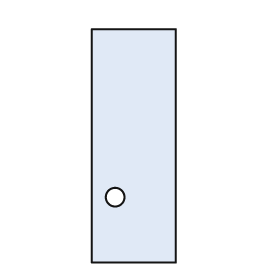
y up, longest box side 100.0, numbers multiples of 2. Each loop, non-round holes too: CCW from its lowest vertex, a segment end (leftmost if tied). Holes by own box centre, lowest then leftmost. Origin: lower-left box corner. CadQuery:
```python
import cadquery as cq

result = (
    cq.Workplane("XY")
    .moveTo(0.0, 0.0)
    .lineTo(36.0, 0.0)
    .lineTo(36.0, 100.0)
    .lineTo(0.0, 100.0)
    .close()
    .moveTo(10.0, 28.0)
    .circle(4.0)
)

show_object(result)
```